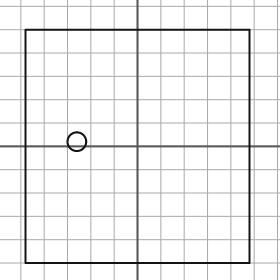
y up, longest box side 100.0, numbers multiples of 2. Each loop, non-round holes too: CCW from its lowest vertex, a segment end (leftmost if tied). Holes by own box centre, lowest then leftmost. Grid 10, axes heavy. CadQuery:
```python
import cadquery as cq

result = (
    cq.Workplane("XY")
    .moveTo(-48.0, -50.0)
    .lineTo(48.0, -50.0)
    .lineTo(48.0, 50.0)
    .lineTo(-48.0, 50.0)
    .close()
    .moveTo(-26.0, 2.0)
    .circle(4.0)
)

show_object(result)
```